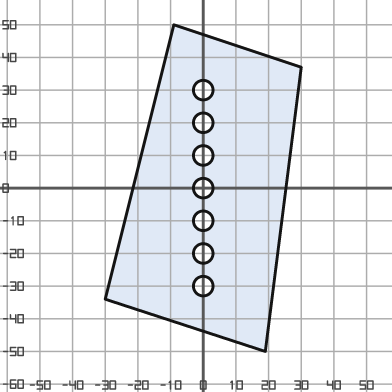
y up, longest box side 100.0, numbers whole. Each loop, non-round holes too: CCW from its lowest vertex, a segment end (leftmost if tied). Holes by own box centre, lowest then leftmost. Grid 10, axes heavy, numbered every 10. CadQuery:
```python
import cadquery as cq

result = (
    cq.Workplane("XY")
    .moveTo(19.0, -50.0)
    .lineTo(30.0, 37.0)
    .lineTo(-9.0, 50.0)
    .lineTo(-30.0, -34.0)
    .close()
    .moveTo(0.0, -30.0)
    .circle(3.0)
    .moveTo(0.0, -20.0)
    .circle(3.0)
    .moveTo(0.0, -10.0)
    .circle(3.0)
    .moveTo(0.0, 0.0)
    .circle(3.0)
    .moveTo(0.0, 10.0)
    .circle(3.0)
    .moveTo(0.0, 20.0)
    .circle(3.0)
    .moveTo(0.0, 30.0)
    .circle(3.0)
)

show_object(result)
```